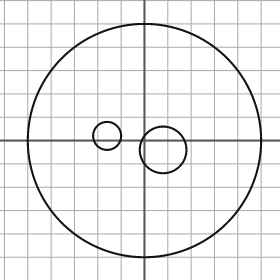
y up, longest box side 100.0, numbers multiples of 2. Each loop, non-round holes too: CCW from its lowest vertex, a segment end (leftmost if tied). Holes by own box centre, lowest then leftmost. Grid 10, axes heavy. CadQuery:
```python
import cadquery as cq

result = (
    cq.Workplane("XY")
    .moveTo(0.0, 0.0)
    .circle(50.0)
    .moveTo(8.0, -4.0)
    .circle(10.0)
    .moveTo(-16.0, 2.0)
    .circle(6.0)
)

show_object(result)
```